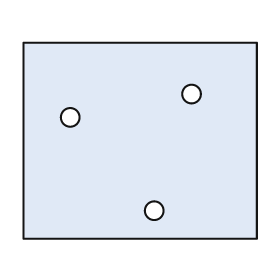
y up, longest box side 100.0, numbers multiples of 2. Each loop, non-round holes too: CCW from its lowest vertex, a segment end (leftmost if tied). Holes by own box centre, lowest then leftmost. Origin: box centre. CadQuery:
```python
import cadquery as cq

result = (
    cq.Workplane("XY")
    .moveTo(-50.0, -42.0)
    .lineTo(50.0, -42.0)
    .lineTo(50.0, 42.0)
    .lineTo(-50.0, 42.0)
    .close()
    .moveTo(6.0, -30.0)
    .circle(4.0)
    .moveTo(-30.0, 10.0)
    .circle(4.0)
    .moveTo(22.0, 20.0)
    .circle(4.0)
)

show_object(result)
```